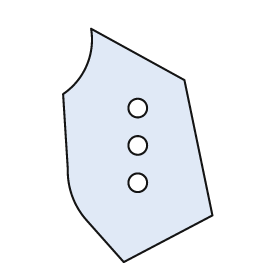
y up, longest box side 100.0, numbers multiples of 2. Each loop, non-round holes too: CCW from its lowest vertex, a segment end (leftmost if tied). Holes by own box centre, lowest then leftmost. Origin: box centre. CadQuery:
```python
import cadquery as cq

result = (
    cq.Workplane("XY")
    .moveTo(-6.0, -50.0)
    .lineTo(32.0, -30.0)
    .lineTo(20.0, 28.0)
    .lineTo(-20.0, 50.0)
    .threePointArc((-22.0, 34.0), (-32.0, 22.0))
    .lineTo(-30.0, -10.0)
    .threePointArc((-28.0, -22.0), (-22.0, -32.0))
    .close()
    .moveTo(0.0, -16.0)
    .circle(4.0)
    .moveTo(0.0, 0.0)
    .circle(4.0)
    .moveTo(0.0, 16.0)
    .circle(4.0)
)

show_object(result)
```